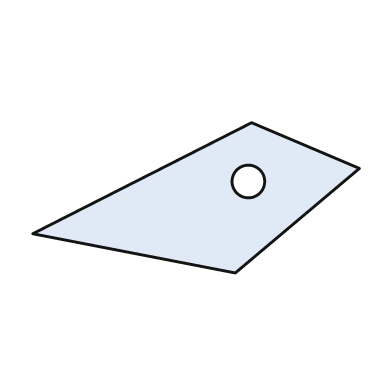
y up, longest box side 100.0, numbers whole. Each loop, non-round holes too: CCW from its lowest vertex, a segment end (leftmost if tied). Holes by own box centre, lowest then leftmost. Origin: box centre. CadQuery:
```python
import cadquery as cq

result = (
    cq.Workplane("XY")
    .moveTo(12.0, -23.0)
    .lineTo(50.0, 9.0)
    .lineTo(17.0, 23.0)
    .lineTo(-50.0, -11.0)
    .close()
    .moveTo(16.0, 5.0)
    .circle(5.0)
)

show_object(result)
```